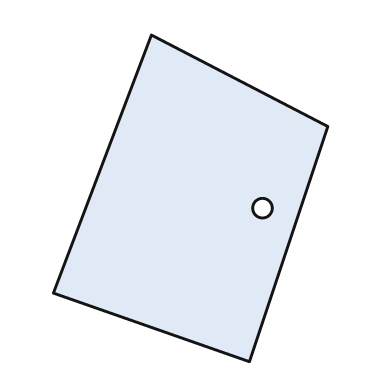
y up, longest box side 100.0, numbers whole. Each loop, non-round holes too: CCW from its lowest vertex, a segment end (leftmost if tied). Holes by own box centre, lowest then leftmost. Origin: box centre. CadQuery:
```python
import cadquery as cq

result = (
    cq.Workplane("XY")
    .moveTo(18.0, -50.0)
    .lineTo(42.0, 22.0)
    .lineTo(-12.0, 50.0)
    .lineTo(-42.0, -29.0)
    .close()
    .moveTo(22.0, -3.0)
    .circle(3.0)
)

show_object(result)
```